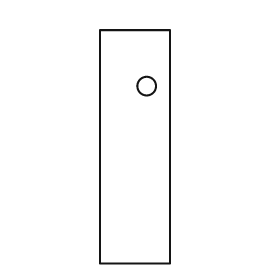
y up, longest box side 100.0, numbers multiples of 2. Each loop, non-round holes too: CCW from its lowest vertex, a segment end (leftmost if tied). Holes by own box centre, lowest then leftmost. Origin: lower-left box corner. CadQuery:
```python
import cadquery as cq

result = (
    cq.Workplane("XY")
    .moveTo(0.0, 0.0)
    .lineTo(30.0, 0.0)
    .lineTo(30.0, 100.0)
    .lineTo(0.0, 100.0)
    .close()
    .moveTo(20.0, 76.0)
    .circle(4.0)
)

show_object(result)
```